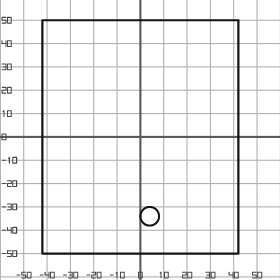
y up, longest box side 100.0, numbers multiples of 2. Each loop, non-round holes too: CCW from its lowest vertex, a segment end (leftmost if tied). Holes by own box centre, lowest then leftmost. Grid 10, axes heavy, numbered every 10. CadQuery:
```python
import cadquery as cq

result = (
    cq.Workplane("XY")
    .moveTo(-42.0, -50.0)
    .lineTo(42.0, -50.0)
    .lineTo(42.0, 50.0)
    .lineTo(-42.0, 50.0)
    .close()
    .moveTo(4.0, -34.0)
    .circle(4.0)
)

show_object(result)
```